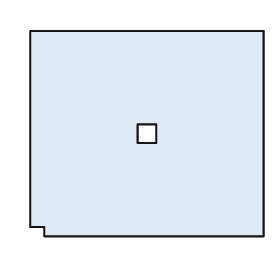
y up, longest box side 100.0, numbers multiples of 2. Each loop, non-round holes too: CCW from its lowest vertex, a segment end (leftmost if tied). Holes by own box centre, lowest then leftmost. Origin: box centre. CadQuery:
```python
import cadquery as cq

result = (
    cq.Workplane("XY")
    .moveTo(-44.0, -44.0)
    .lineTo(50.0, -44.0)
    .lineTo(50.0, 44.0)
    .lineTo(-50.0, 44.0)
    .lineTo(-50.0, -40.0)
    .lineTo(-44.0, -40.0)
    .close()
    .moveTo(-4.0, -4.0)
    .lineTo(4.0, -4.0)
    .lineTo(4.0, 4.0)
    .lineTo(-4.0, 4.0)
    .close()
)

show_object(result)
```